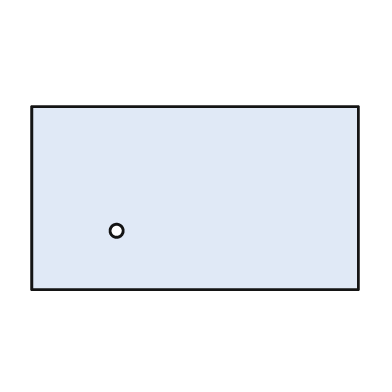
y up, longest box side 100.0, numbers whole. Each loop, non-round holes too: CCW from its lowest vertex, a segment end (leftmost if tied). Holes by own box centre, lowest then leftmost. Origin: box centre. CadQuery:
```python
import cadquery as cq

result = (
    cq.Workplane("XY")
    .moveTo(-50.0, -28.0)
    .lineTo(50.0, -28.0)
    .lineTo(50.0, 28.0)
    .lineTo(-50.0, 28.0)
    .close()
    .moveTo(-24.0, -10.0)
    .circle(2.0)
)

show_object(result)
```